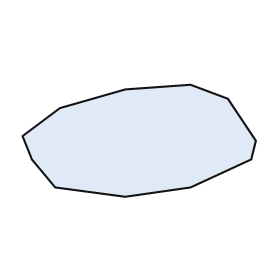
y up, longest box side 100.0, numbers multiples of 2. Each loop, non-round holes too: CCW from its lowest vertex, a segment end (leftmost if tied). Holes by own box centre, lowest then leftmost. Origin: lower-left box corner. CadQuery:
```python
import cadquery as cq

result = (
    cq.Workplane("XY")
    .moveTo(44.0, 0.0)
    .lineTo(72.0, 4.0)
    .lineTo(98.0, 16.0)
    .lineTo(100.0, 24.0)
    .lineTo(88.0, 42.0)
    .lineTo(72.0, 48.0)
    .lineTo(44.0, 46.0)
    .lineTo(16.0, 38.0)
    .lineTo(0.0, 26.0)
    .lineTo(4.0, 16.0)
    .lineTo(14.0, 4.0)
    .close()
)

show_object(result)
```